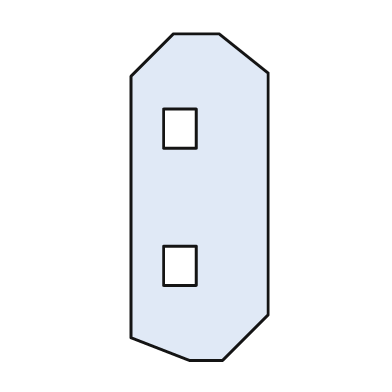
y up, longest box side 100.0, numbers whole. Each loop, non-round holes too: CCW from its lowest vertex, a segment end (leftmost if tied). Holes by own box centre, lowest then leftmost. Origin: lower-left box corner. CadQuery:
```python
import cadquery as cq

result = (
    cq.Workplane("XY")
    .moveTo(18.0, 0.0)
    .lineTo(28.0, 0.0)
    .lineTo(42.0, 14.0)
    .lineTo(42.0, 88.0)
    .lineTo(27.0, 100.0)
    .lineTo(13.0, 100.0)
    .lineTo(0.0, 87.0)
    .lineTo(0.0, 7.0)
    .close()
    .moveTo(10.0, 23.0)
    .lineTo(20.0, 23.0)
    .lineTo(20.0, 35.0)
    .lineTo(10.0, 35.0)
    .close()
    .moveTo(10.0, 65.0)
    .lineTo(20.0, 65.0)
    .lineTo(20.0, 77.0)
    .lineTo(10.0, 77.0)
    .close()
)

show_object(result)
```